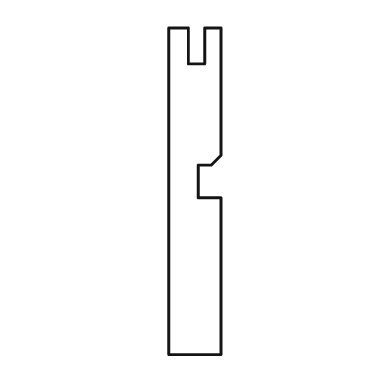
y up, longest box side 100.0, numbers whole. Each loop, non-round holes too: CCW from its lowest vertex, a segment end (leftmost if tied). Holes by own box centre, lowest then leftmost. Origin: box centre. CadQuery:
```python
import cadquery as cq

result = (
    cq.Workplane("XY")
    .moveTo(-8.0, -50.0)
    .lineTo(8.0, -50.0)
    .lineTo(8.0, -2.0)
    .lineTo(1.0, -2.0)
    .lineTo(1.0, 8.0)
    .lineTo(5.0, 8.0)
    .lineTo(8.0, 11.0)
    .lineTo(8.0, 50.0)
    .lineTo(3.0, 50.0)
    .lineTo(3.0, 39.0)
    .lineTo(-2.0, 39.0)
    .lineTo(-2.0, 50.0)
    .lineTo(-8.0, 50.0)
    .close()
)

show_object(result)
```